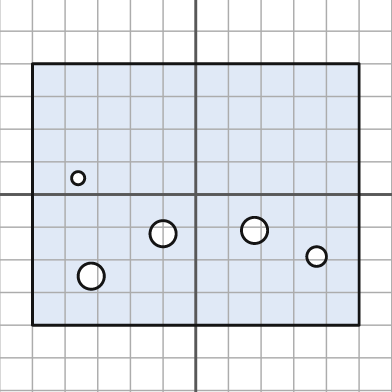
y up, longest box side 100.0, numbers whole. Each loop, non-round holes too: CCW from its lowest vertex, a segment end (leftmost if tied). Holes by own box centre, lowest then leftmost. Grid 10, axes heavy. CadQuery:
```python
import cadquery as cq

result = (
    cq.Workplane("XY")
    .moveTo(-50.0, -40.0)
    .lineTo(50.0, -40.0)
    .lineTo(50.0, 40.0)
    .lineTo(-50.0, 40.0)
    .close()
    .moveTo(-32.0, -25.0)
    .circle(4.0)
    .moveTo(37.0, -19.0)
    .circle(3.0)
    .moveTo(-10.0, -12.0)
    .circle(4.0)
    .moveTo(18.0, -11.0)
    .circle(4.0)
    .moveTo(-36.0, 5.0)
    .circle(2.0)
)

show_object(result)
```